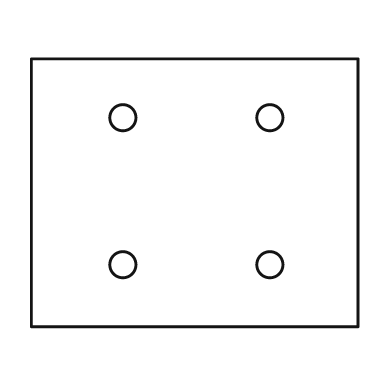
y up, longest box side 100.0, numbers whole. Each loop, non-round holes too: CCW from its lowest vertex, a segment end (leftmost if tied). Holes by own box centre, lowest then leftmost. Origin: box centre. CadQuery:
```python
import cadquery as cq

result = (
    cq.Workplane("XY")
    .moveTo(-50.0, -41.0)
    .lineTo(50.0, -41.0)
    .lineTo(50.0, 41.0)
    .lineTo(-50.0, 41.0)
    .close()
    .moveTo(-22.0, -22.0)
    .circle(4.0)
    .moveTo(23.0, -22.0)
    .circle(4.0)
    .moveTo(-22.0, 23.0)
    .circle(4.0)
    .moveTo(23.0, 23.0)
    .circle(4.0)
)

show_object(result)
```